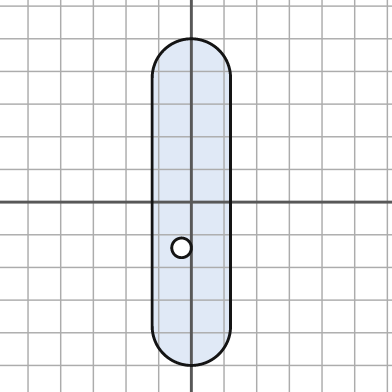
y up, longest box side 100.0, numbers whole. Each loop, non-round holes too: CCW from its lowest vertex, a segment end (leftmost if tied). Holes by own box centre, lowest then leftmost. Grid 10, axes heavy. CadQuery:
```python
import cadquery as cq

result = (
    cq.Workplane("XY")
    .moveTo(-12.0, -38.0)
    .threePointArc((0.0, -50.0), (12.0, -38.0))
    .lineTo(12.0, 38.0)
    .threePointArc((0.0, 50.0), (-12.0, 38.0))
    .close()
    .moveTo(-3.0, -14.0)
    .circle(3.0)
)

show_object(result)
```